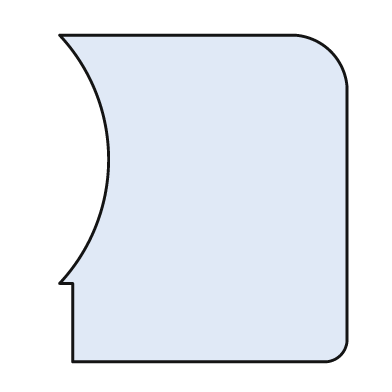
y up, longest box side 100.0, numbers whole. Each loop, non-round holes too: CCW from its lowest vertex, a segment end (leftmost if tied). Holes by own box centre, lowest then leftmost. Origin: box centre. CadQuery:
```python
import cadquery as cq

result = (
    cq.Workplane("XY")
    .moveTo(-40.0, -50.0)
    .lineTo(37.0, -50.0)
    .threePointArc((42.0, -48.0), (44.0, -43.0))
    .lineTo(44.0, 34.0)
    .threePointArc((39.0, 45.0), (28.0, 50.0))
    .lineTo(-44.0, 50.0)
    .threePointArc((-29.0, 12.0), (-44.0, -26.0))
    .lineTo(-40.0, -26.0)
    .close()
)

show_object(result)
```